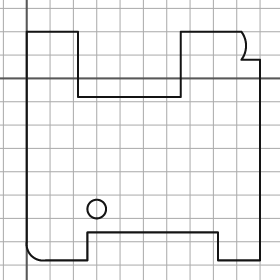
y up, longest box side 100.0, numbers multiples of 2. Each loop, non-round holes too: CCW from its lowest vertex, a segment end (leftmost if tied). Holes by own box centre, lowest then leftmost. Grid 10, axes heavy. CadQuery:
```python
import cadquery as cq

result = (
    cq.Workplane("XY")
    .moveTo(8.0, -78.0)
    .lineTo(26.0, -78.0)
    .lineTo(26.0, -66.0)
    .lineTo(82.0, -66.0)
    .lineTo(82.0, -78.0)
    .lineTo(100.0, -78.0)
    .lineTo(100.0, 8.0)
    .lineTo(92.0, 8.0)
    .threePointArc((94.0, 14.0), (92.0, 20.0))
    .lineTo(66.0, 20.0)
    .lineTo(66.0, -8.0)
    .lineTo(22.0, -8.0)
    .lineTo(22.0, 20.0)
    .lineTo(0.0, 20.0)
    .lineTo(0.0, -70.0)
    .threePointArc((2.0, -76.0), (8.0, -78.0))
    .close()
    .moveTo(30.0, -56.0)
    .circle(4.0)
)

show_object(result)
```